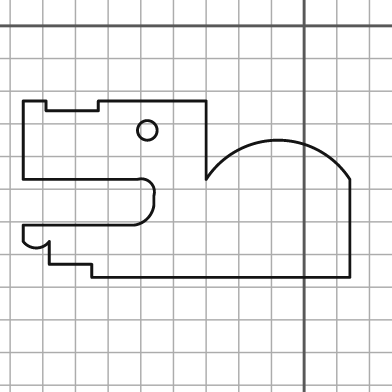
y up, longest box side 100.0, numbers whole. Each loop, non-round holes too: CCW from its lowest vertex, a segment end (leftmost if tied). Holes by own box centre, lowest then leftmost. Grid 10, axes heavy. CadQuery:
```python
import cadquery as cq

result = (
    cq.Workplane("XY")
    .moveTo(-65.0, -77.0)
    .lineTo(14.0, -77.0)
    .lineTo(14.0, -47.0)
    .threePointArc((-8.0, -35.0), (-30.0, -47.0))
    .lineTo(-30.0, -23.0)
    .lineTo(-63.0, -23.0)
    .lineTo(-63.0, -26.0)
    .lineTo(-79.0, -26.0)
    .lineTo(-79.0, -23.0)
    .lineTo(-86.0, -23.0)
    .lineTo(-86.0, -47.0)
    .lineTo(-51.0, -47.0)
    .threePointArc((-47.0, -48.0), (-46.0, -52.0))
    .lineTo(-46.0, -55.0)
    .threePointArc((-48.0, -59.0), (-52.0, -61.0))
    .lineTo(-86.0, -61.0)
    .lineTo(-86.0, -66.0)
    .threePointArc((-82.0, -68.0), (-78.0, -66.0))
    .lineTo(-78.0, -73.0)
    .lineTo(-65.0, -73.0)
    .close()
    .moveTo(-48.0, -32.0)
    .circle(3.0)
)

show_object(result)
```